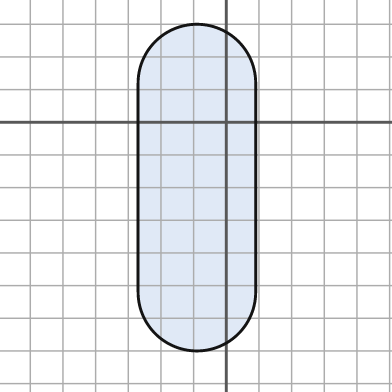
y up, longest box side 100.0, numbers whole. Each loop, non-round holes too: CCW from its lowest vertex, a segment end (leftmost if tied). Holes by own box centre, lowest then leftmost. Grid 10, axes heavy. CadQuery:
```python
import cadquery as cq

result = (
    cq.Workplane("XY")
    .moveTo(-27.0, -52.0)
    .threePointArc((-9.0, -70.0), (9.0, -52.0))
    .lineTo(9.0, 12.0)
    .threePointArc((-9.0, 30.0), (-27.0, 12.0))
    .close()
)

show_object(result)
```